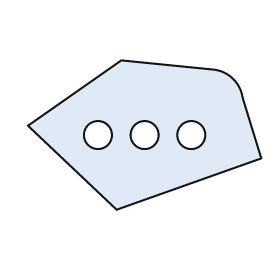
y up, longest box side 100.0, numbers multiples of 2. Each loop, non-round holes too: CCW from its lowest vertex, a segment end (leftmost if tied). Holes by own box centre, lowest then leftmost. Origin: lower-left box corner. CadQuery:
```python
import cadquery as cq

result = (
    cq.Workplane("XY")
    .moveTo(38.0, 0.0)
    .lineTo(100.0, 22.0)
    .lineTo(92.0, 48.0)
    .threePointArc((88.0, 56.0), (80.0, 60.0))
    .lineTo(40.0, 64.0)
    .lineTo(0.0, 36.0)
    .close()
    .moveTo(30.0, 32.0)
    .circle(6.0)
    .moveTo(50.0, 32.0)
    .circle(6.0)
    .moveTo(70.0, 32.0)
    .circle(6.0)
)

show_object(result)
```